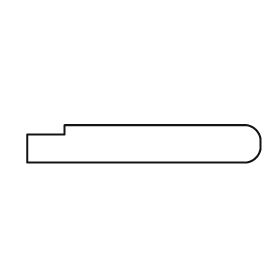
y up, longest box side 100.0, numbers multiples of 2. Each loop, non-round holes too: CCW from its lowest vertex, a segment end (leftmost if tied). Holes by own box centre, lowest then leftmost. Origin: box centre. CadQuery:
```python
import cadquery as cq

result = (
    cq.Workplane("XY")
    .moveTo(-50.0, -8.0)
    .lineTo(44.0, -8.0)
    .threePointArc((48.0, -6.0), (50.0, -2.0))
    .lineTo(50.0, 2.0)
    .threePointArc((48.0, 6.0), (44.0, 8.0))
    .lineTo(-34.0, 8.0)
    .lineTo(-34.0, 4.0)
    .lineTo(-50.0, 4.0)
    .close()
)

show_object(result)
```